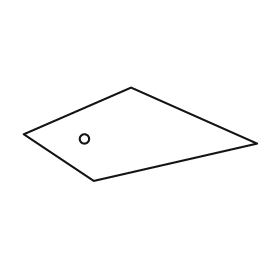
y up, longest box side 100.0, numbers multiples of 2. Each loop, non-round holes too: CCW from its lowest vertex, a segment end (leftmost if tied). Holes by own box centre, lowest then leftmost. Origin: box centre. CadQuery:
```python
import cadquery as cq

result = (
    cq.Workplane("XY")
    .moveTo(-20.0, -20.0)
    .lineTo(50.0, -4.0)
    .lineTo(-4.0, 20.0)
    .lineTo(-50.0, 0.0)
    .close()
    .moveTo(-24.0, -2.0)
    .circle(2.0)
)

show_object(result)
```